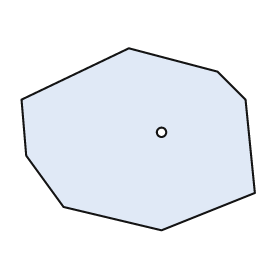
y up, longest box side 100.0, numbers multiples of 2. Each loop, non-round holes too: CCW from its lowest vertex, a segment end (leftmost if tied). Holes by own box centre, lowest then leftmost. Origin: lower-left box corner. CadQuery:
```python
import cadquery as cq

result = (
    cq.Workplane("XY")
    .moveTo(60.0, 0.0)
    .lineTo(100.0, 16.0)
    .lineTo(96.0, 56.0)
    .lineTo(84.0, 68.0)
    .lineTo(46.0, 78.0)
    .lineTo(0.0, 56.0)
    .lineTo(2.0, 32.0)
    .lineTo(18.0, 10.0)
    .close()
    .moveTo(60.0, 42.0)
    .circle(2.0)
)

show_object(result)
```